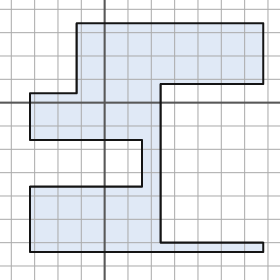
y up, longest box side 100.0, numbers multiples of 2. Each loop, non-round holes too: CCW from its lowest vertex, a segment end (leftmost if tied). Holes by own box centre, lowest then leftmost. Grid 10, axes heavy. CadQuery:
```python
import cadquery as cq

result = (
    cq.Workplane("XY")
    .moveTo(-32.0, -64.0)
    .lineTo(68.0, -64.0)
    .lineTo(68.0, -60.0)
    .lineTo(24.0, -60.0)
    .lineTo(24.0, 8.0)
    .lineTo(68.0, 8.0)
    .lineTo(68.0, 34.0)
    .lineTo(-12.0, 34.0)
    .lineTo(-12.0, 4.0)
    .lineTo(-32.0, 4.0)
    .lineTo(-32.0, -16.0)
    .lineTo(16.0, -16.0)
    .lineTo(16.0, -36.0)
    .lineTo(-32.0, -36.0)
    .close()
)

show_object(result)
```